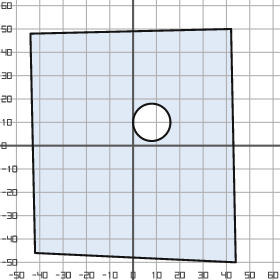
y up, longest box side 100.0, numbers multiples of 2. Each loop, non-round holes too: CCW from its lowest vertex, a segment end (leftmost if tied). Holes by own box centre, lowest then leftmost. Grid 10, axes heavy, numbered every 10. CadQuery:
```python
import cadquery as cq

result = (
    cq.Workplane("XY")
    .moveTo(44.0, -50.0)
    .lineTo(42.0, 50.0)
    .lineTo(-44.0, 48.0)
    .lineTo(-42.0, -46.0)
    .close()
    .moveTo(8.0, 10.0)
    .circle(8.0)
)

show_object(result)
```